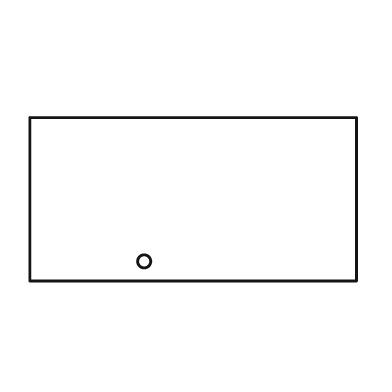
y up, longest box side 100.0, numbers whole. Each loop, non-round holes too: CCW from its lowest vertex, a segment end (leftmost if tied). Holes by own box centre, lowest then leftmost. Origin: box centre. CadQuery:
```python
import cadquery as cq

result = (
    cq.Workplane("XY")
    .moveTo(-50.0, -25.0)
    .lineTo(50.0, -25.0)
    .lineTo(50.0, 25.0)
    .lineTo(-50.0, 25.0)
    .close()
    .moveTo(-15.0, -19.0)
    .circle(2.0)
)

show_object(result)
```